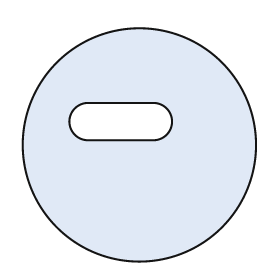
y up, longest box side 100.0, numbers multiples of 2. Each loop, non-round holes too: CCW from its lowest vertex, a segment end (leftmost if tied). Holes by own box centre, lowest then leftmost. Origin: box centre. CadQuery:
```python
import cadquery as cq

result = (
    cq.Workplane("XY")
    .moveTo(0.0, 0.0)
    .circle(50.0)
    .moveTo(-22.0, 2.0)
    .lineTo(6.0, 2.0)
    .threePointArc((14.0, 10.0), (6.0, 18.0))
    .lineTo(-22.0, 18.0)
    .threePointArc((-30.0, 10.0), (-22.0, 2.0))
    .close()
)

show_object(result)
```